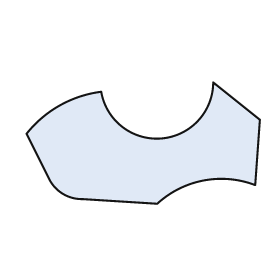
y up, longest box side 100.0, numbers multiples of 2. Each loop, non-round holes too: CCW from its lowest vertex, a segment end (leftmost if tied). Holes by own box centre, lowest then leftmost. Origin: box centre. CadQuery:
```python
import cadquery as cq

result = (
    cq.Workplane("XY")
    .moveTo(6.0, -26.0)
    .threePointArc((26.0, -16.0), (48.0, -18.0))
    .lineTo(50.0, 10.0)
    .lineTo(30.0, 26.0)
    .threePointArc((8.0, 2.0), (-18.0, 22.0))
    .threePointArc((-36.0, 16.0), (-50.0, 4.0))
    .lineTo(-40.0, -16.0)
    .threePointArc((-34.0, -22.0), (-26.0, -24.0))
    .close()
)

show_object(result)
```